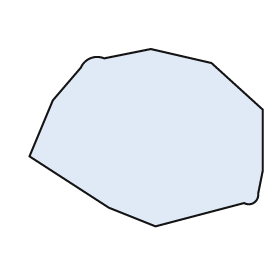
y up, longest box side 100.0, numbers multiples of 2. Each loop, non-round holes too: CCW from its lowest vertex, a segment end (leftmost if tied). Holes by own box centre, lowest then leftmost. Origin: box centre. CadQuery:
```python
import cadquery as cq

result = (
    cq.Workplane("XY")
    .moveTo(4.0, -38.0)
    .lineTo(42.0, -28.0)
    .threePointArc((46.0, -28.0), (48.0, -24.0))
    .lineTo(50.0, -14.0)
    .lineTo(50.0, 12.0)
    .lineTo(28.0, 32.0)
    .lineTo(2.0, 38.0)
    .lineTo(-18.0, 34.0)
    .threePointArc((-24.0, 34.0), (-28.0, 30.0))
    .lineTo(-40.0, 16.0)
    .lineTo(-50.0, -8.0)
    .lineTo(-16.0, -30.0)
    .close()
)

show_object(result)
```